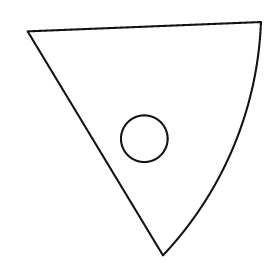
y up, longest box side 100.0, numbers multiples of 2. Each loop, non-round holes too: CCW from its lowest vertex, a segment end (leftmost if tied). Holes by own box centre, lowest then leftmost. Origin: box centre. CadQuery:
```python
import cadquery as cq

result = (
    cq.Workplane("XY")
    .moveTo(8.0, -50.0)
    .threePointArc((38.0, -4.0), (50.0, 50.0))
    .lineTo(-50.0, 46.0)
    .close()
    .moveTo(0.0, 0.0)
    .circle(10.0)
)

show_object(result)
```